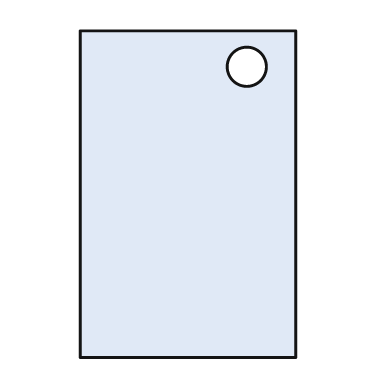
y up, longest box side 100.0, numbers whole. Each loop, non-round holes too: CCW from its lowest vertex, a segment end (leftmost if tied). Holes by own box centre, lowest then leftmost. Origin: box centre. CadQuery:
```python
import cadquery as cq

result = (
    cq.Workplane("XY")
    .moveTo(-33.0, -50.0)
    .lineTo(33.0, -50.0)
    .lineTo(33.0, 50.0)
    .lineTo(-33.0, 50.0)
    .close()
    .moveTo(18.0, 39.0)
    .circle(6.0)
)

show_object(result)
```